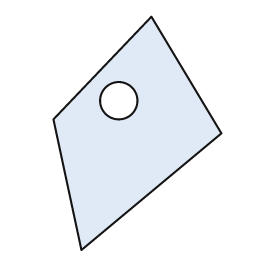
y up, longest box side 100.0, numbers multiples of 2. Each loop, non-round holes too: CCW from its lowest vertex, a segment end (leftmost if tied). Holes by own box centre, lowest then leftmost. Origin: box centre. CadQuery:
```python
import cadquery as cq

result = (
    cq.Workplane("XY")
    .moveTo(-24.0, -50.0)
    .lineTo(36.0, 0.0)
    .lineTo(6.0, 50.0)
    .lineTo(-36.0, 6.0)
    .close()
    .moveTo(-8.0, 14.0)
    .circle(8.0)
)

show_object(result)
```